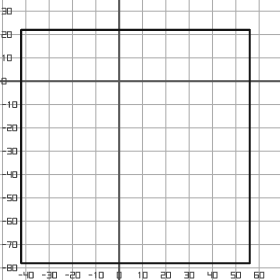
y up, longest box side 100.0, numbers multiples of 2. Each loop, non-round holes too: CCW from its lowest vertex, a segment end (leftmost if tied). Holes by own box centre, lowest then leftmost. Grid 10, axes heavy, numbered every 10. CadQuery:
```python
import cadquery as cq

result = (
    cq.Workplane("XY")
    .moveTo(-42.0, -78.0)
    .lineTo(56.0, -78.0)
    .lineTo(56.0, 22.0)
    .lineTo(-42.0, 22.0)
    .close()
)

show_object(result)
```